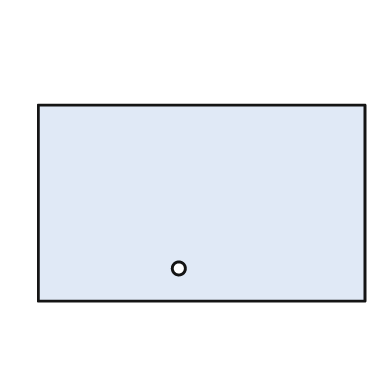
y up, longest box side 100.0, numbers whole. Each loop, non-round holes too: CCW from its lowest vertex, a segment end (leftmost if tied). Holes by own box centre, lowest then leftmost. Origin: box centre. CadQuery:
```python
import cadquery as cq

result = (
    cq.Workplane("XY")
    .moveTo(-50.0, -30.0)
    .lineTo(50.0, -30.0)
    .lineTo(50.0, 30.0)
    .lineTo(-50.0, 30.0)
    .close()
    .moveTo(-7.0, -20.0)
    .circle(2.0)
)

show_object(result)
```